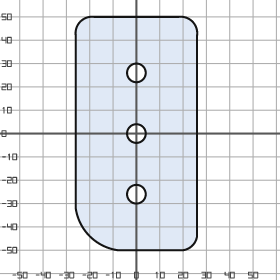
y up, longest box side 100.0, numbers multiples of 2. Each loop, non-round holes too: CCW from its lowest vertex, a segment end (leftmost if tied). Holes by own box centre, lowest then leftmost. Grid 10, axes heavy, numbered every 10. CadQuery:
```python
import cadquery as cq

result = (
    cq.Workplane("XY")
    .moveTo(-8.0, -50.0)
    .lineTo(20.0, -50.0)
    .threePointArc((24.0, -48.0), (26.0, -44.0))
    .lineTo(26.0, 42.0)
    .threePointArc((24.0, 48.0), (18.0, 50.0))
    .lineTo(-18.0, 50.0)
    .threePointArc((-24.0, 48.0), (-26.0, 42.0))
    .lineTo(-26.0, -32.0)
    .threePointArc((-20.0, -44.0), (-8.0, -50.0))
    .close()
    .moveTo(0.0, -26.0)
    .circle(4.0)
    .moveTo(0.0, 0.0)
    .circle(4.0)
    .moveTo(0.0, 26.0)
    .circle(4.0)
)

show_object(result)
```